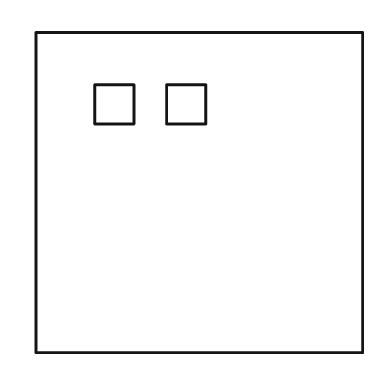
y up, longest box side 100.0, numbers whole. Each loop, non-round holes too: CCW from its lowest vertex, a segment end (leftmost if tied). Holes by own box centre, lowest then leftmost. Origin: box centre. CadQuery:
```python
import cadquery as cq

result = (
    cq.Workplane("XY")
    .moveTo(-50.0, -49.0)
    .lineTo(50.0, -49.0)
    .lineTo(50.0, 49.0)
    .lineTo(-50.0, 49.0)
    .close()
    .moveTo(-32.0, 21.0)
    .lineTo(-20.0, 21.0)
    .lineTo(-20.0, 33.0)
    .lineTo(-32.0, 33.0)
    .close()
    .moveTo(-10.0, 21.0)
    .lineTo(2.0, 21.0)
    .lineTo(2.0, 33.0)
    .lineTo(-10.0, 33.0)
    .close()
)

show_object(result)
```